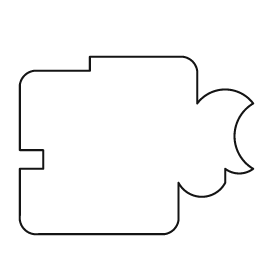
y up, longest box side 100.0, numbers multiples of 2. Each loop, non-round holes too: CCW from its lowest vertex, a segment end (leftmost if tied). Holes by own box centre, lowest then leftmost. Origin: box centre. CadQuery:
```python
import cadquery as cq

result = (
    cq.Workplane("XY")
    .moveTo(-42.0, -38.0)
    .lineTo(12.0, -38.0)
    .threePointArc((16.0, -36.0), (18.0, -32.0))
    .lineTo(18.0, -16.0)
    .threePointArc((28.0, -22.0), (38.0, -16.0))
    .lineTo(38.0, -10.0)
    .threePointArc((44.0, -12.0), (50.0, -10.0))
    .threePointArc((42.0, 4.0), (50.0, 18.0))
    .threePointArc((38.0, 24.0), (26.0, 18.0))
    .lineTo(26.0, 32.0)
    .threePointArc((24.0, 36.0), (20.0, 38.0))
    .lineTo(-20.0, 38.0)
    .lineTo(-20.0, 32.0)
    .lineTo(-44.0, 32.0)
    .threePointArc((-48.0, 30.0), (-50.0, 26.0))
    .lineTo(-50.0, -2.0)
    .lineTo(-40.0, -2.0)
    .lineTo(-40.0, -10.0)
    .lineTo(-50.0, -10.0)
    .lineTo(-50.0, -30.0)
    .threePointArc((-48.0, -36.0), (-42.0, -38.0))
    .close()
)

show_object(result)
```